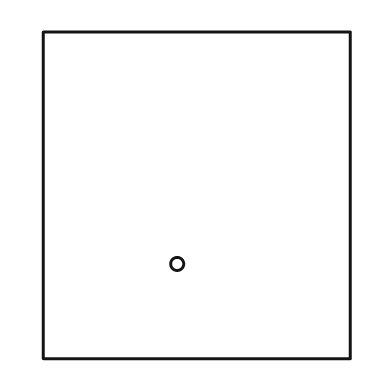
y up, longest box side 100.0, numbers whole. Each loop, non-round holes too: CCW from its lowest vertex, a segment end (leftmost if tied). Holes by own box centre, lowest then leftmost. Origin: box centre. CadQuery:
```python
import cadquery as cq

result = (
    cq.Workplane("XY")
    .moveTo(-47.0, -50.0)
    .lineTo(47.0, -50.0)
    .lineTo(47.0, 50.0)
    .lineTo(-47.0, 50.0)
    .close()
    .moveTo(-6.0, -21.0)
    .circle(2.0)
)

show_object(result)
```